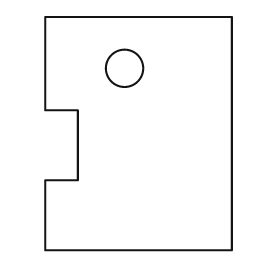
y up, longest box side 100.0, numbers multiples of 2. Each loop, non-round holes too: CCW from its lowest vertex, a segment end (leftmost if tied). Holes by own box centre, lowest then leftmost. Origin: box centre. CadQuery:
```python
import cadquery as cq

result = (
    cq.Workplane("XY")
    .moveTo(-40.0, -50.0)
    .lineTo(40.0, -50.0)
    .lineTo(40.0, 50.0)
    .lineTo(-40.0, 50.0)
    .lineTo(-40.0, 10.0)
    .lineTo(-26.0, 10.0)
    .lineTo(-26.0, -20.0)
    .lineTo(-40.0, -20.0)
    .close()
    .moveTo(-6.0, 28.0)
    .circle(8.0)
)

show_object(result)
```